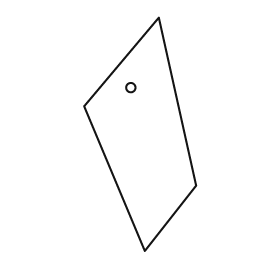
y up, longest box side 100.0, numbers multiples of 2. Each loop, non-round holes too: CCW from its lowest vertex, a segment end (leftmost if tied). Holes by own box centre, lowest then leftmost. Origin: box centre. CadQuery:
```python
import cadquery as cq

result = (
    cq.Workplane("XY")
    .moveTo(2.0, -50.0)
    .lineTo(24.0, -22.0)
    .lineTo(8.0, 50.0)
    .lineTo(-24.0, 12.0)
    .close()
    .moveTo(-4.0, 20.0)
    .circle(2.0)
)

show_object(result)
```